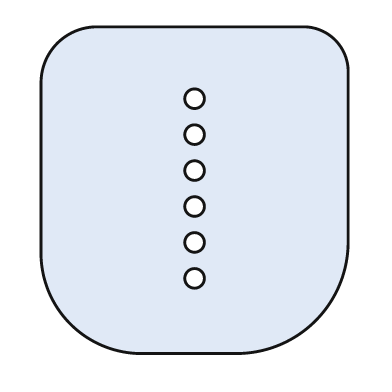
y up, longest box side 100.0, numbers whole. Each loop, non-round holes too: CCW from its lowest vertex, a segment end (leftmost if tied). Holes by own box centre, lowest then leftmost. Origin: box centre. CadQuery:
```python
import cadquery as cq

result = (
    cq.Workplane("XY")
    .moveTo(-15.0, -50.0)
    .lineTo(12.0, -50.0)
    .threePointArc((37.0, -40.0), (47.0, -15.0))
    .lineTo(47.0, 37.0)
    .threePointArc((43.0, 46.0), (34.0, 50.0))
    .lineTo(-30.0, 50.0)
    .threePointArc((-42.0, 45.0), (-47.0, 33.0))
    .lineTo(-47.0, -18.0)
    .threePointArc((-38.0, -41.0), (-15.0, -50.0))
    .close()
    .moveTo(0.0, -27.0)
    .circle(3.0)
    .moveTo(0.0, -16.0)
    .circle(3.0)
    .moveTo(0.0, -5.0)
    .circle(3.0)
    .moveTo(0.0, 6.0)
    .circle(3.0)
    .moveTo(0.0, 17.0)
    .circle(3.0)
    .moveTo(0.0, 28.0)
    .circle(3.0)
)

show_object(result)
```